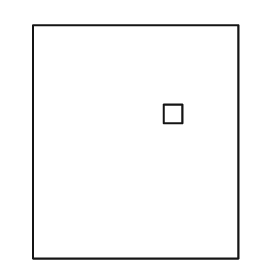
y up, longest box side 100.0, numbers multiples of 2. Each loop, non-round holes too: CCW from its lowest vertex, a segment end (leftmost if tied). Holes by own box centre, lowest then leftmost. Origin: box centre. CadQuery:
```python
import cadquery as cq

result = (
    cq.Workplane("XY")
    .moveTo(-44.0, -50.0)
    .lineTo(44.0, -50.0)
    .lineTo(44.0, 50.0)
    .lineTo(-44.0, 50.0)
    .close()
    .moveTo(12.0, 8.0)
    .lineTo(20.0, 8.0)
    .lineTo(20.0, 16.0)
    .lineTo(12.0, 16.0)
    .close()
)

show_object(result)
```